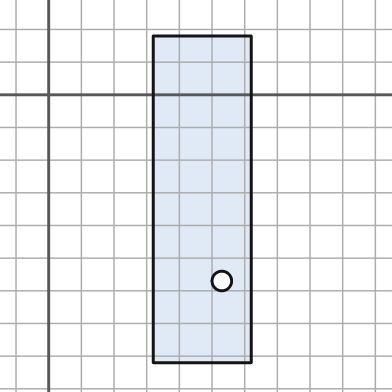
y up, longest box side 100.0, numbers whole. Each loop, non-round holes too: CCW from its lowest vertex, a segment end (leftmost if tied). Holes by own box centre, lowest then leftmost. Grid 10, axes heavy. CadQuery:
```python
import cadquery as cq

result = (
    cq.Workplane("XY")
    .moveTo(32.0, -82.0)
    .lineTo(62.0, -82.0)
    .lineTo(62.0, 18.0)
    .lineTo(32.0, 18.0)
    .close()
    .moveTo(53.0, -57.0)
    .circle(3.0)
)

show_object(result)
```